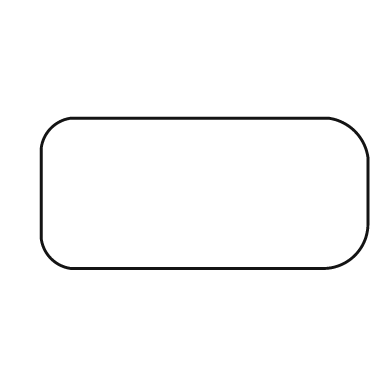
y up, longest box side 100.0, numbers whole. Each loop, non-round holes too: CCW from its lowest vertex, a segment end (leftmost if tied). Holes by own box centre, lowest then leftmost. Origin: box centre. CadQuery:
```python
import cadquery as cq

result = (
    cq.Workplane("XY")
    .moveTo(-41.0, -23.0)
    .lineTo(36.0, -23.0)
    .threePointArc((46.0, -19.0), (50.0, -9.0))
    .lineTo(50.0, 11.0)
    .threePointArc((46.0, 19.0), (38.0, 23.0))
    .lineTo(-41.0, 23.0)
    .threePointArc((-47.0, 20.0), (-50.0, 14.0))
    .lineTo(-50.0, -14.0)
    .threePointArc((-47.0, -20.0), (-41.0, -23.0))
    .close()
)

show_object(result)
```